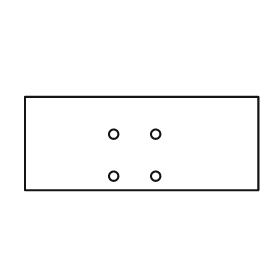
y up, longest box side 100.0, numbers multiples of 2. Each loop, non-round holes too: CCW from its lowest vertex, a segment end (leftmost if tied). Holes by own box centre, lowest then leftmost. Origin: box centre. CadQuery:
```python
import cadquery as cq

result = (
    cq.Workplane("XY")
    .moveTo(-50.0, -20.0)
    .lineTo(50.0, -20.0)
    .lineTo(50.0, 20.0)
    .lineTo(-50.0, 20.0)
    .close()
    .moveTo(-12.0, -14.0)
    .circle(2.0)
    .moveTo(6.0, -14.0)
    .circle(2.0)
    .moveTo(-12.0, 4.0)
    .circle(2.0)
    .moveTo(6.0, 4.0)
    .circle(2.0)
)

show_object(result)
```